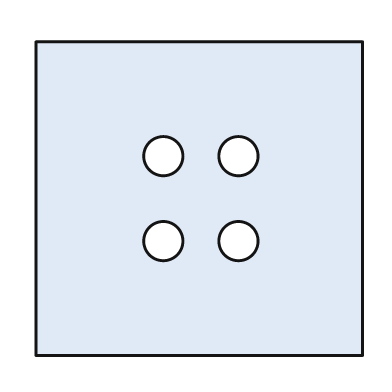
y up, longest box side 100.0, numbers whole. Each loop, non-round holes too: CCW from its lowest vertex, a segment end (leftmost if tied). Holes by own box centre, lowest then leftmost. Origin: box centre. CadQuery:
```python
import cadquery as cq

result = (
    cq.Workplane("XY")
    .moveTo(-50.0, -48.0)
    .lineTo(50.0, -48.0)
    .lineTo(50.0, 48.0)
    .lineTo(-50.0, 48.0)
    .close()
    .moveTo(-11.0, -13.0)
    .circle(6.0)
    .moveTo(12.0, -13.0)
    .circle(6.0)
    .moveTo(-11.0, 13.0)
    .circle(6.0)
    .moveTo(12.0, 13.0)
    .circle(6.0)
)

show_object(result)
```